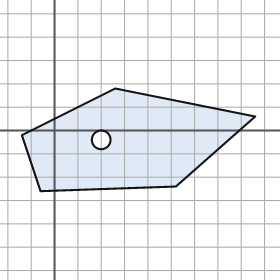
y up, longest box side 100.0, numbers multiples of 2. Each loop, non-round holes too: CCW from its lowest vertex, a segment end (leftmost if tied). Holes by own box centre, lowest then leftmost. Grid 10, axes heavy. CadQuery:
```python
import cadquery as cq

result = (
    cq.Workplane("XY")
    .moveTo(-6.0, -26.0)
    .lineTo(52.0, -24.0)
    .lineTo(86.0, 6.0)
    .lineTo(26.0, 18.0)
    .lineTo(-14.0, -2.0)
    .close()
    .moveTo(20.0, -4.0)
    .circle(4.0)
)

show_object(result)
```